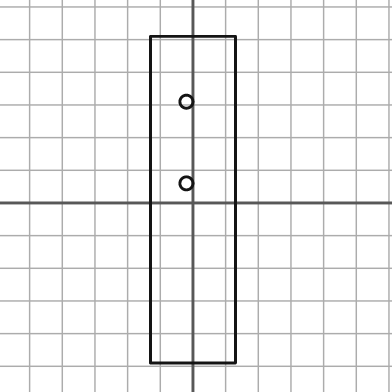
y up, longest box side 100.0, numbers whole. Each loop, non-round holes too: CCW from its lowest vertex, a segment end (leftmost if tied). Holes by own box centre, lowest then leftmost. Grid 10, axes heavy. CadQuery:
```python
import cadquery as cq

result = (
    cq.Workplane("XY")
    .moveTo(-13.0, -49.0)
    .lineTo(13.0, -49.0)
    .lineTo(13.0, 51.0)
    .lineTo(-13.0, 51.0)
    .close()
    .moveTo(-2.0, 6.0)
    .circle(2.0)
    .moveTo(-2.0, 31.0)
    .circle(2.0)
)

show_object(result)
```